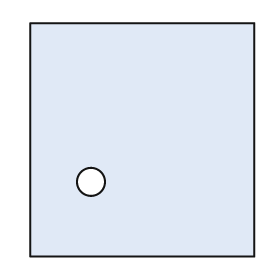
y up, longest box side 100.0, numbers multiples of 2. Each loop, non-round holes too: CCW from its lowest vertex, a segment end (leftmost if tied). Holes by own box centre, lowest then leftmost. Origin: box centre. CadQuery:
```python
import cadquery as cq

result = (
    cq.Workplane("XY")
    .moveTo(-48.0, -50.0)
    .lineTo(48.0, -50.0)
    .lineTo(48.0, 50.0)
    .lineTo(-48.0, 50.0)
    .close()
    .moveTo(-22.0, -18.0)
    .circle(6.0)
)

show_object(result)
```